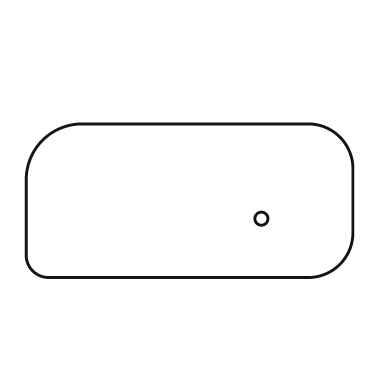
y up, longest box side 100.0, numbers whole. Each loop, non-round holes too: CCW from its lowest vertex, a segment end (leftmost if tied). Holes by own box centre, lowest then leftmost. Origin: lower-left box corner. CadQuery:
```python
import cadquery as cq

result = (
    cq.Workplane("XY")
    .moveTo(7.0, 0.0)
    .lineTo(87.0, 0.0)
    .threePointArc((96.0, 4.0), (100.0, 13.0))
    .lineTo(100.0, 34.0)
    .threePointArc((96.0, 43.0), (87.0, 47.0))
    .lineTo(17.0, 47.0)
    .threePointArc((5.0, 42.0), (0.0, 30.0))
    .lineTo(0.0, 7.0)
    .threePointArc((2.0, 2.0), (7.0, 0.0))
    .close()
    .moveTo(72.0, 18.0)
    .circle(2.0)
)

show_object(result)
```